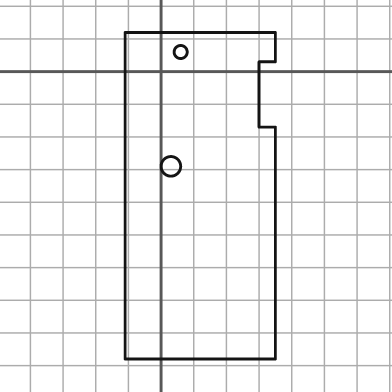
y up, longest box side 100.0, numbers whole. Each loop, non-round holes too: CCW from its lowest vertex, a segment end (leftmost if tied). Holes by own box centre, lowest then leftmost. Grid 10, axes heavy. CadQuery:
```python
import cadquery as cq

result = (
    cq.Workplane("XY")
    .moveTo(-11.0, -88.0)
    .lineTo(35.0, -88.0)
    .lineTo(35.0, -17.0)
    .lineTo(30.0, -17.0)
    .lineTo(30.0, 3.0)
    .lineTo(35.0, 3.0)
    .lineTo(35.0, 12.0)
    .lineTo(-11.0, 12.0)
    .close()
    .moveTo(3.0, -29.0)
    .circle(3.0)
    .moveTo(6.0, 6.0)
    .circle(2.0)
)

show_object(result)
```